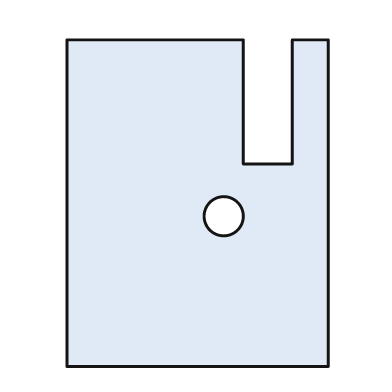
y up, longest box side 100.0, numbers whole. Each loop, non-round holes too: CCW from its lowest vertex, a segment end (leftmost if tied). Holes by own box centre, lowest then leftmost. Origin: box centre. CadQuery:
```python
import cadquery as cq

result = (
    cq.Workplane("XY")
    .moveTo(-40.0, -50.0)
    .lineTo(40.0, -50.0)
    .lineTo(40.0, 50.0)
    .lineTo(29.0, 50.0)
    .lineTo(29.0, 12.0)
    .lineTo(14.0, 12.0)
    .lineTo(14.0, 50.0)
    .lineTo(-40.0, 50.0)
    .close()
    .moveTo(8.0, -4.0)
    .circle(6.0)
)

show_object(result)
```